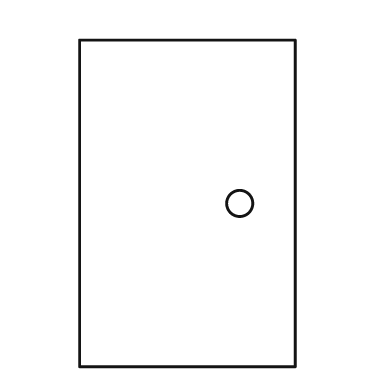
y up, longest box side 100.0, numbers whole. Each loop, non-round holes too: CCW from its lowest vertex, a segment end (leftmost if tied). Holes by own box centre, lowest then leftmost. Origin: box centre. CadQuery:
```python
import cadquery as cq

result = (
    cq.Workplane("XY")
    .moveTo(-33.0, -50.0)
    .lineTo(33.0, -50.0)
    .lineTo(33.0, 50.0)
    .lineTo(-33.0, 50.0)
    .close()
    .moveTo(16.0, 0.0)
    .circle(4.0)
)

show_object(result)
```